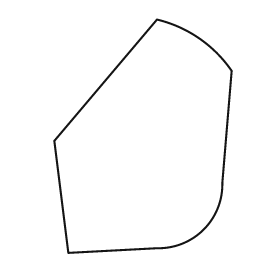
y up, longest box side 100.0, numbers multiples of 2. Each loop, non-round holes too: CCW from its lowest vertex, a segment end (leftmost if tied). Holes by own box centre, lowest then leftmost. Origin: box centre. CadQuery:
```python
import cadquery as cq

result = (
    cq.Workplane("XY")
    .moveTo(-32.0, -50.0)
    .lineTo(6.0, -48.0)
    .threePointArc((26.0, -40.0), (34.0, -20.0))
    .lineTo(38.0, 28.0)
    .threePointArc((24.0, 42.0), (6.0, 50.0))
    .lineTo(-38.0, -2.0)
    .close()
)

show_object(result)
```